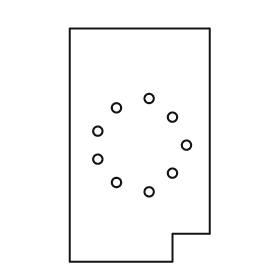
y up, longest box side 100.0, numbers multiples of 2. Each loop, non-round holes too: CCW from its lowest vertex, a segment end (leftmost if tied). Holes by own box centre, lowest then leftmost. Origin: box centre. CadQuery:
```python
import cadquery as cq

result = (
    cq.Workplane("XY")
    .moveTo(-30.0, -50.0)
    .lineTo(14.0, -50.0)
    .lineTo(14.0, -38.0)
    .lineTo(30.0, -38.0)
    .lineTo(30.0, 50.0)
    .lineTo(-30.0, 50.0)
    .close()
    .moveTo(4.0, -20.0)
    .circle(2.0)
    .moveTo(-10.0, -16.0)
    .circle(2.0)
    .moveTo(14.0, -12.0)
    .circle(2.0)
    .moveTo(-18.0, -6.0)
    .circle(2.0)
    .moveTo(20.0, 0.0)
    .circle(2.0)
    .moveTo(-18.0, 6.0)
    .circle(2.0)
    .moveTo(14.0, 12.0)
    .circle(2.0)
    .moveTo(-10.0, 16.0)
    .circle(2.0)
    .moveTo(4.0, 20.0)
    .circle(2.0)
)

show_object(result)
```